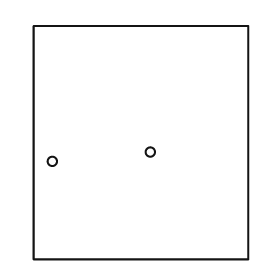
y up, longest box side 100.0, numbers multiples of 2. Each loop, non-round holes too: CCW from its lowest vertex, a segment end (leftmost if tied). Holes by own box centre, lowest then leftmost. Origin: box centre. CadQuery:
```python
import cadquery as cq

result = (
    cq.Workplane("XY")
    .moveTo(-46.0, -50.0)
    .lineTo(46.0, -50.0)
    .lineTo(46.0, 50.0)
    .lineTo(-46.0, 50.0)
    .close()
    .moveTo(-38.0, -8.0)
    .circle(2.0)
    .moveTo(4.0, -4.0)
    .circle(2.0)
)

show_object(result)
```